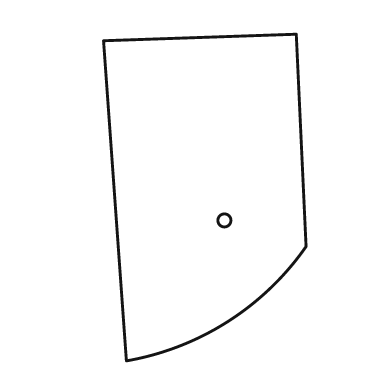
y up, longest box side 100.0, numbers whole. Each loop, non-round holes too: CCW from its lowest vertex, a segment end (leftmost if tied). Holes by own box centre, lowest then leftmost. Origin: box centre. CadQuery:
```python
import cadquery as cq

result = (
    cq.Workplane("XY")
    .moveTo(-24.0, -50.0)
    .threePointArc((7.0, -38.0), (31.0, -15.0))
    .lineTo(28.0, 50.0)
    .lineTo(-31.0, 48.0)
    .close()
    .moveTo(6.0, -7.0)
    .circle(2.0)
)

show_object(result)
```